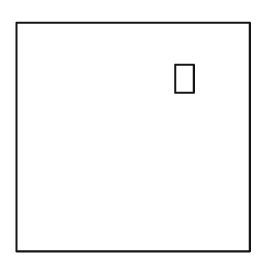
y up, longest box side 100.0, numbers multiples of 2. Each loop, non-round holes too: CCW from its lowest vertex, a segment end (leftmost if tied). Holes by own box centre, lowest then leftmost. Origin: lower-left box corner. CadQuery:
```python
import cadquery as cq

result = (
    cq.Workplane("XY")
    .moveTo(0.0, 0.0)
    .lineTo(100.0, 0.0)
    .lineTo(100.0, 98.0)
    .lineTo(0.0, 98.0)
    .close()
    .moveTo(68.0, 68.0)
    .lineTo(76.0, 68.0)
    .lineTo(76.0, 80.0)
    .lineTo(68.0, 80.0)
    .close()
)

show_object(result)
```